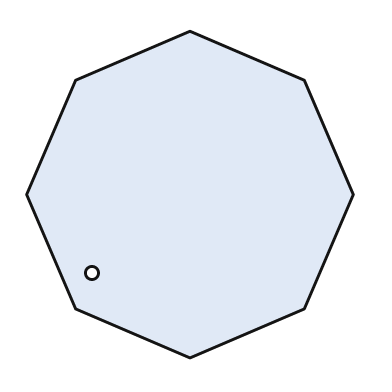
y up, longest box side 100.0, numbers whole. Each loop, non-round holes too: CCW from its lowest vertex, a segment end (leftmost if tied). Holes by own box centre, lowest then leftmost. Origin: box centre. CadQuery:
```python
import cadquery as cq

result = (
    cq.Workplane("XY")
    .moveTo(0.0, -50.0)
    .lineTo(35.0, -35.0)
    .lineTo(50.0, 0.0)
    .lineTo(35.0, 35.0)
    .lineTo(0.0, 50.0)
    .lineTo(-35.0, 35.0)
    .lineTo(-50.0, 0.0)
    .lineTo(-35.0, -35.0)
    .close()
    .moveTo(-30.0, -24.0)
    .circle(2.0)
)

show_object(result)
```